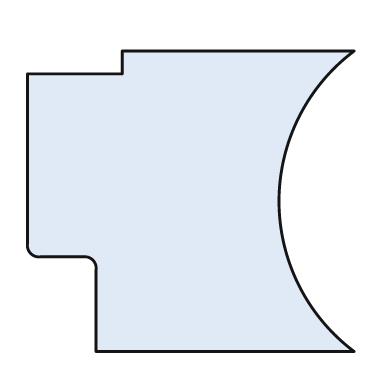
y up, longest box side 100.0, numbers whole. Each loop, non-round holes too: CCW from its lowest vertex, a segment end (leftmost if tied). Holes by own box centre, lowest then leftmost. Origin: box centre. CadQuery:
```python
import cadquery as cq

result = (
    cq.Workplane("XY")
    .moveTo(-29.0, -46.0)
    .lineTo(50.0, -46.0)
    .threePointArc((27.0, 0.0), (50.0, 46.0))
    .lineTo(-21.0, 46.0)
    .lineTo(-21.0, 39.0)
    .lineTo(-50.0, 39.0)
    .lineTo(-50.0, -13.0)
    .threePointArc((-49.0, -16.0), (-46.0, -17.0))
    .lineTo(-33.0, -17.0)
    .threePointArc((-30.0, -18.0), (-29.0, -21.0))
    .close()
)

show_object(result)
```